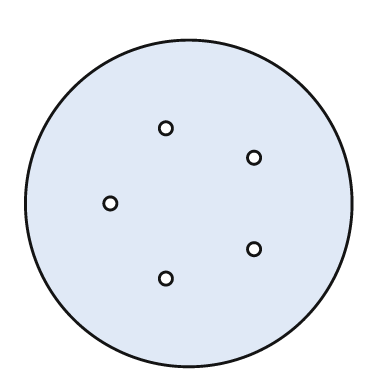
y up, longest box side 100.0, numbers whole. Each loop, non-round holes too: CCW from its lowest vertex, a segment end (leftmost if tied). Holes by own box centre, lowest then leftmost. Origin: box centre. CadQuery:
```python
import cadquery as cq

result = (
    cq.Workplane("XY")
    .moveTo(0.0, 0.0)
    .circle(50.0)
    .moveTo(-7.0, -23.0)
    .circle(2.0)
    .moveTo(20.0, -14.0)
    .circle(2.0)
    .moveTo(-24.0, 0.0)
    .circle(2.0)
    .moveTo(20.0, 14.0)
    .circle(2.0)
    .moveTo(-7.0, 23.0)
    .circle(2.0)
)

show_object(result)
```